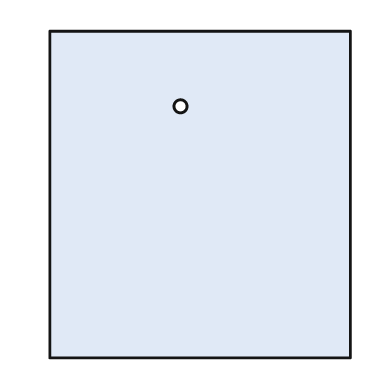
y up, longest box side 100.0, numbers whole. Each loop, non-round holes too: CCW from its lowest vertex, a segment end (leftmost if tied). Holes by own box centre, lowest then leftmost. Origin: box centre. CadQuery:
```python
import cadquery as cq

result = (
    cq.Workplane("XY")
    .moveTo(-46.0, -50.0)
    .lineTo(46.0, -50.0)
    .lineTo(46.0, 50.0)
    .lineTo(-46.0, 50.0)
    .close()
    .moveTo(-6.0, 27.0)
    .circle(2.0)
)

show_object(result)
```